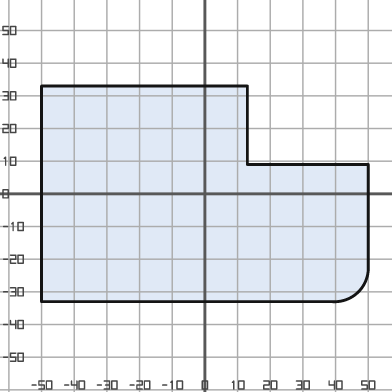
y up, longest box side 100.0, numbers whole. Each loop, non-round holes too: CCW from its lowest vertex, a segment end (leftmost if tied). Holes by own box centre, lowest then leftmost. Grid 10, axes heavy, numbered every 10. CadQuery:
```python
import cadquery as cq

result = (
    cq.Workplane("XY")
    .moveTo(-50.0, -33.0)
    .lineTo(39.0, -33.0)
    .threePointArc((47.0, -30.0), (50.0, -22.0))
    .lineTo(50.0, 9.0)
    .lineTo(13.0, 9.0)
    .lineTo(13.0, 33.0)
    .lineTo(-50.0, 33.0)
    .close()
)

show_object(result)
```